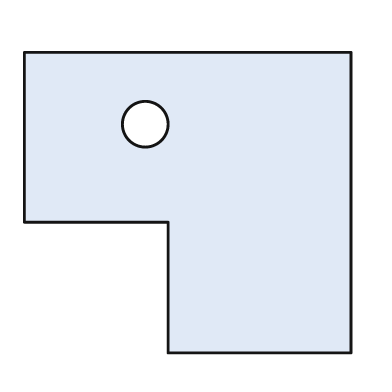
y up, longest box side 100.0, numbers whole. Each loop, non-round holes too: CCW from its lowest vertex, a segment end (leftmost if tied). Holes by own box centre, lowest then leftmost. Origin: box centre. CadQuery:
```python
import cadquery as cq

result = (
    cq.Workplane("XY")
    .moveTo(-6.0, -46.0)
    .lineTo(50.0, -46.0)
    .lineTo(50.0, 46.0)
    .lineTo(-50.0, 46.0)
    .lineTo(-50.0, -6.0)
    .lineTo(-6.0, -6.0)
    .close()
    .moveTo(-13.0, 24.0)
    .circle(7.0)
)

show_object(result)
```